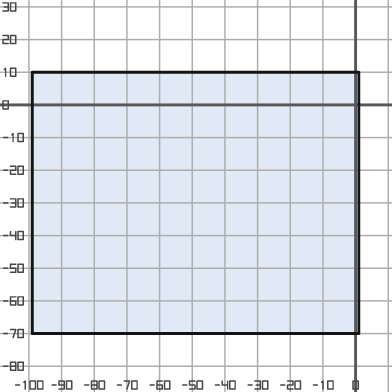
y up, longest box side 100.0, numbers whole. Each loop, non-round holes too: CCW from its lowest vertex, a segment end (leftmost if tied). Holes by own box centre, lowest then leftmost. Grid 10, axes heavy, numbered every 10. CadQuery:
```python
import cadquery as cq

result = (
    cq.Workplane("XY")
    .moveTo(-99.0, -70.0)
    .lineTo(1.0, -70.0)
    .lineTo(1.0, 10.0)
    .lineTo(-99.0, 10.0)
    .close()
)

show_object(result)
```